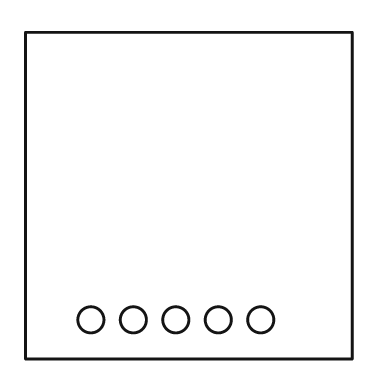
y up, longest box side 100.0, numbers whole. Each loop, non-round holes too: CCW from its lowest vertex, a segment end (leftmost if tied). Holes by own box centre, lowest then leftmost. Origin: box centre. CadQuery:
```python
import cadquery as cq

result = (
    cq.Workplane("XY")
    .moveTo(-50.0, -50.0)
    .lineTo(50.0, -50.0)
    .lineTo(50.0, 50.0)
    .lineTo(-50.0, 50.0)
    .close()
    .moveTo(-30.0, -38.0)
    .circle(4.0)
    .moveTo(-17.0, -38.0)
    .circle(4.0)
    .moveTo(-4.0, -38.0)
    .circle(4.0)
    .moveTo(9.0, -38.0)
    .circle(4.0)
    .moveTo(22.0, -38.0)
    .circle(4.0)
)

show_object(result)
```